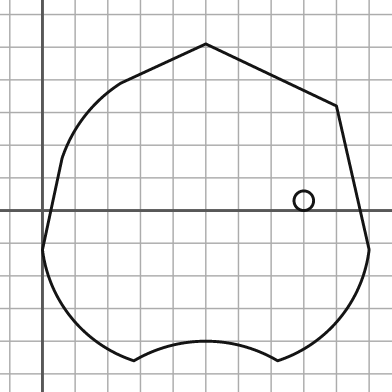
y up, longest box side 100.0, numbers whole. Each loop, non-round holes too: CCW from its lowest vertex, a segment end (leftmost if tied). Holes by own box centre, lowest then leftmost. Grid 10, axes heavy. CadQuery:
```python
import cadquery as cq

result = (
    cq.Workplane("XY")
    .moveTo(28.0, -46.0)
    .threePointArc((50.0, -40.0), (72.0, -46.0))
    .threePointArc((91.0, -33.0), (100.0, -12.0))
    .lineTo(90.0, 32.0)
    .lineTo(50.0, 51.0)
    .lineTo(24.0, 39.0)
    .threePointArc((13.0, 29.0), (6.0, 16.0))
    .lineTo(0.0, -12.0)
    .threePointArc((9.0, -33.0), (28.0, -46.0))
    .close()
    .moveTo(80.0, 3.0)
    .circle(3.0)
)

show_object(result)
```